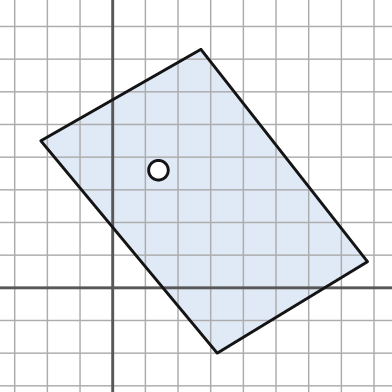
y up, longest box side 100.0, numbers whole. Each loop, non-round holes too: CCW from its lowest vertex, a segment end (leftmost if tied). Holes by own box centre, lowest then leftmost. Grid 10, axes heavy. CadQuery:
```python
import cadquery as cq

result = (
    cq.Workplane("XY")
    .moveTo(32.0, -20.0)
    .lineTo(78.0, 8.0)
    .lineTo(27.0, 73.0)
    .lineTo(-22.0, 45.0)
    .close()
    .moveTo(14.0, 36.0)
    .circle(3.0)
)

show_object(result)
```